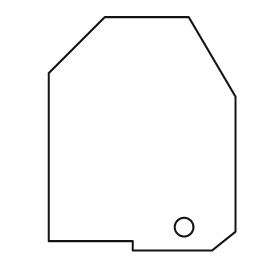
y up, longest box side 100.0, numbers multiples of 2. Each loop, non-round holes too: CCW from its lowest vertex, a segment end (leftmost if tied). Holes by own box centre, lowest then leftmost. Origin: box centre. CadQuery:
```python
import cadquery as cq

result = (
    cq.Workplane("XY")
    .moveTo(-4.0, -50.0)
    .lineTo(30.0, -50.0)
    .lineTo(40.0, -42.0)
    .lineTo(40.0, 16.0)
    .lineTo(20.0, 50.0)
    .lineTo(-16.0, 50.0)
    .lineTo(-40.0, 26.0)
    .lineTo(-40.0, -46.0)
    .lineTo(-4.0, -46.0)
    .close()
    .moveTo(18.0, -40.0)
    .circle(4.0)
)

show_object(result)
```